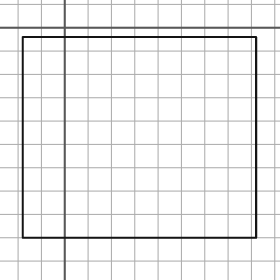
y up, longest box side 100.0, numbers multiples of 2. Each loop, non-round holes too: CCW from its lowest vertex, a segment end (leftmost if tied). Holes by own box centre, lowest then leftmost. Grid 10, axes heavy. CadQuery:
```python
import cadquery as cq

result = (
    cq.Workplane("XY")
    .moveTo(-18.0, -90.0)
    .lineTo(82.0, -90.0)
    .lineTo(82.0, -4.0)
    .lineTo(-18.0, -4.0)
    .close()
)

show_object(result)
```